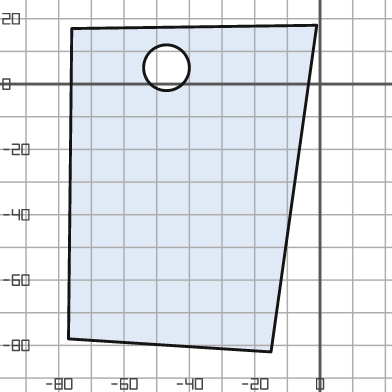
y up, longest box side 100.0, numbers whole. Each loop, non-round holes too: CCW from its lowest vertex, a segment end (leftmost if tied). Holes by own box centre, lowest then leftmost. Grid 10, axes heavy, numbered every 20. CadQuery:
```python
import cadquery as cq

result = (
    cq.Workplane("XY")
    .moveTo(-15.0, -82.0)
    .lineTo(-1.0, 18.0)
    .lineTo(-76.0, 17.0)
    .lineTo(-77.0, -78.0)
    .close()
    .moveTo(-47.0, 5.0)
    .circle(7.0)
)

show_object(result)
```